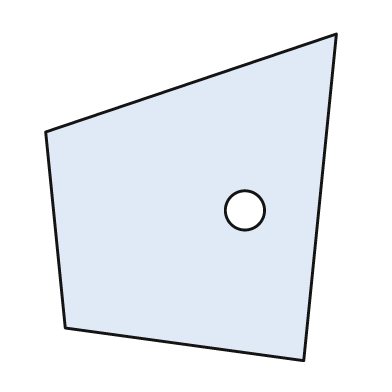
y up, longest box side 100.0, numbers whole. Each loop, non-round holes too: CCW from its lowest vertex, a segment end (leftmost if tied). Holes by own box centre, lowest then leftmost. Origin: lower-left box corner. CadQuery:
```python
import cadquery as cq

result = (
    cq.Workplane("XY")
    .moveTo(79.0, 0.0)
    .lineTo(89.0, 100.0)
    .lineTo(0.0, 70.0)
    .lineTo(6.0, 10.0)
    .close()
    .moveTo(61.0, 46.0)
    .circle(6.0)
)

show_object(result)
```